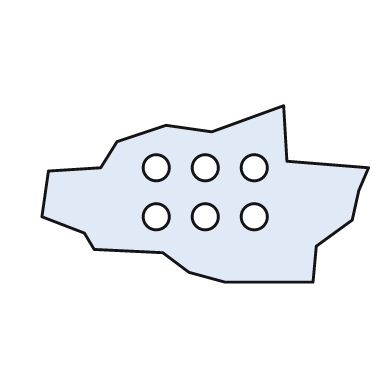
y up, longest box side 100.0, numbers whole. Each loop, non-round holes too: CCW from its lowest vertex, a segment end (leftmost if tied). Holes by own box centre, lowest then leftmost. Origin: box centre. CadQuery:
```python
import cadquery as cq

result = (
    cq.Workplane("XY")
    .moveTo(6.0, -27.0)
    .lineTo(33.0, -27.0)
    .lineTo(34.0, -16.0)
    .lineTo(45.0, -8.0)
    .lineTo(47.0, 1.0)
    .lineTo(50.0, 8.0)
    .lineTo(25.0, 10.0)
    .lineTo(24.0, 27.0)
    .lineTo(2.0, 19.0)
    .lineTo(-12.0, 21.0)
    .lineTo(-27.0, 16.0)
    .lineTo(-32.0, 8.0)
    .lineTo(-48.0, 7.0)
    .lineTo(-50.0, -7.0)
    .lineTo(-37.0, -12.0)
    .lineTo(-34.0, -17.0)
    .lineTo(-13.0, -18.0)
    .lineTo(-5.0, -24.0)
    .close()
    .moveTo(-15.0, -7.0)
    .circle(4.0)
    .moveTo(0.0, -7.0)
    .circle(4.0)
    .moveTo(15.0, -7.0)
    .circle(4.0)
    .moveTo(-15.0, 8.0)
    .circle(4.0)
    .moveTo(0.0, 8.0)
    .circle(4.0)
    .moveTo(15.0, 8.0)
    .circle(4.0)
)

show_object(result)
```